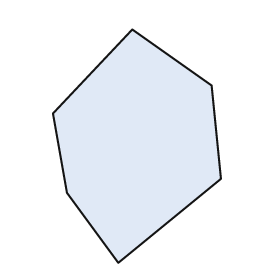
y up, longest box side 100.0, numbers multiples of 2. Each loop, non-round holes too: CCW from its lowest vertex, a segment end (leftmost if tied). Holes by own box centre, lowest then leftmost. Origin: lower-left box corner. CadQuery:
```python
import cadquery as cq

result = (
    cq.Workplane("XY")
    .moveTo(28.0, 0.0)
    .lineTo(72.0, 36.0)
    .lineTo(68.0, 76.0)
    .lineTo(34.0, 100.0)
    .lineTo(0.0, 64.0)
    .lineTo(6.0, 30.0)
    .close()
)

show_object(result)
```